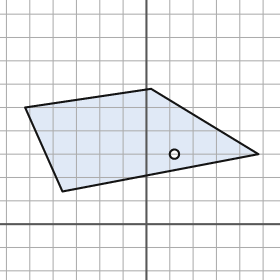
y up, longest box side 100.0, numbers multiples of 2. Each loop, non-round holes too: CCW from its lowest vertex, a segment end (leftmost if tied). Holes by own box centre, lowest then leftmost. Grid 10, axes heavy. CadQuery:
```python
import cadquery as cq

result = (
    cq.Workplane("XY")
    .moveTo(-36.0, 14.0)
    .lineTo(48.0, 30.0)
    .lineTo(2.0, 58.0)
    .lineTo(-52.0, 50.0)
    .close()
    .moveTo(12.0, 30.0)
    .circle(2.0)
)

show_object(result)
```